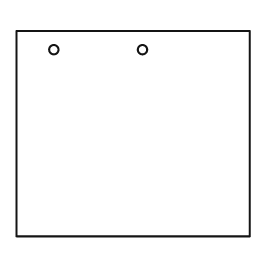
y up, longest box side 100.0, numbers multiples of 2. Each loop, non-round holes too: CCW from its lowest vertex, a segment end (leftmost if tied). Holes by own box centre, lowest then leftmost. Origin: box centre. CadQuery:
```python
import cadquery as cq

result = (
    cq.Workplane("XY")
    .moveTo(-50.0, -44.0)
    .lineTo(50.0, -44.0)
    .lineTo(50.0, 44.0)
    .lineTo(-50.0, 44.0)
    .close()
    .moveTo(-34.0, 36.0)
    .circle(2.0)
    .moveTo(4.0, 36.0)
    .circle(2.0)
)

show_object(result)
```